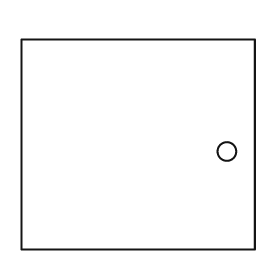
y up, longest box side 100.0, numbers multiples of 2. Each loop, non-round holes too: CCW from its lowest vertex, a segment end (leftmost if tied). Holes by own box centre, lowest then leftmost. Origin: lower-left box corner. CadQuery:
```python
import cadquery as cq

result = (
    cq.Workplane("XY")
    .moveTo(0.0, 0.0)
    .lineTo(100.0, 0.0)
    .lineTo(100.0, 90.0)
    .lineTo(0.0, 90.0)
    .close()
    .moveTo(88.0, 42.0)
    .circle(4.0)
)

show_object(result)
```